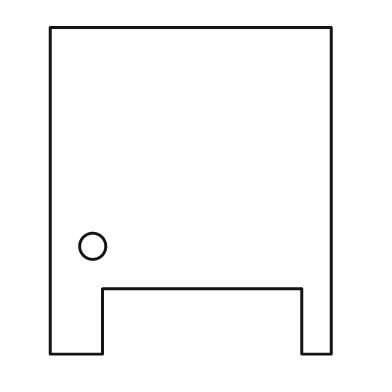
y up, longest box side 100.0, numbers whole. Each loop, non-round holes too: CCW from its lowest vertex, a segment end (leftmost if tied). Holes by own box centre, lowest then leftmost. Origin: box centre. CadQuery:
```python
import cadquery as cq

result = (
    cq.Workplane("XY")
    .moveTo(-43.0, -50.0)
    .lineTo(-27.0, -50.0)
    .lineTo(-27.0, -30.0)
    .lineTo(34.0, -30.0)
    .lineTo(34.0, -50.0)
    .lineTo(43.0, -50.0)
    .lineTo(43.0, 50.0)
    .lineTo(-43.0, 50.0)
    .close()
    .moveTo(-30.0, -17.0)
    .circle(4.0)
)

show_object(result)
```